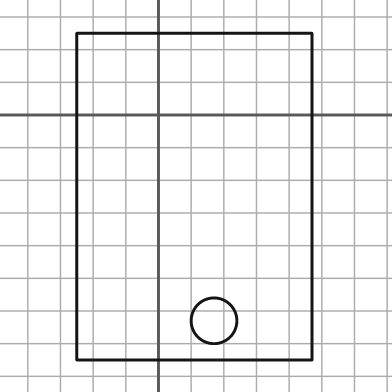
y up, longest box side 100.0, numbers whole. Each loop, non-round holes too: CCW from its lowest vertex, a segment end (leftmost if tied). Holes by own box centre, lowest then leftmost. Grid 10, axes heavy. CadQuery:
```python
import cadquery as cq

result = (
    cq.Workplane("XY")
    .moveTo(-25.0, -75.0)
    .lineTo(47.0, -75.0)
    .lineTo(47.0, 25.0)
    .lineTo(-25.0, 25.0)
    .close()
    .moveTo(17.0, -63.0)
    .circle(7.0)
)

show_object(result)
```